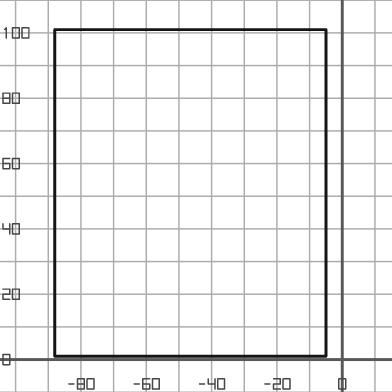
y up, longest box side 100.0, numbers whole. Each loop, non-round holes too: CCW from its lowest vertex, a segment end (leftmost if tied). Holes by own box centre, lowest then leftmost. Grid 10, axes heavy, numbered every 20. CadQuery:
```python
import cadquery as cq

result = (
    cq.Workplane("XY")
    .moveTo(-88.0, 1.0)
    .lineTo(-5.0, 1.0)
    .lineTo(-5.0, 101.0)
    .lineTo(-88.0, 101.0)
    .close()
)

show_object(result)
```